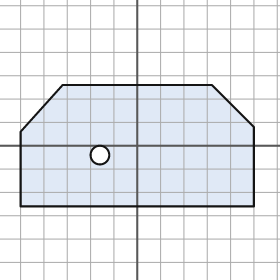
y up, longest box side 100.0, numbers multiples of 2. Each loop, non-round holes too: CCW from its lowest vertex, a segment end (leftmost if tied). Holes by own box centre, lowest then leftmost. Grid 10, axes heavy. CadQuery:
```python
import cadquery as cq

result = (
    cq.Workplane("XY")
    .moveTo(-50.0, -26.0)
    .lineTo(50.0, -26.0)
    .lineTo(50.0, 8.0)
    .lineTo(32.0, 26.0)
    .lineTo(-32.0, 26.0)
    .lineTo(-50.0, 6.0)
    .close()
    .moveTo(-16.0, -4.0)
    .circle(4.0)
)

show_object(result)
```